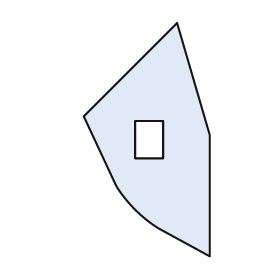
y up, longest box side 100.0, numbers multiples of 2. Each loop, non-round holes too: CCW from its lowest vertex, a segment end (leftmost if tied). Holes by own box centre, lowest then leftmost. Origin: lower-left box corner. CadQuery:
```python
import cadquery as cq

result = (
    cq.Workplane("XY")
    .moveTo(54.0, 0.0)
    .lineTo(54.0, 52.0)
    .lineTo(40.0, 100.0)
    .lineTo(0.0, 60.0)
    .lineTo(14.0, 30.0)
    .threePointArc((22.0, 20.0), (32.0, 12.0))
    .close()
    .moveTo(22.0, 42.0)
    .lineTo(34.0, 42.0)
    .lineTo(34.0, 58.0)
    .lineTo(22.0, 58.0)
    .close()
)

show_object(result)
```